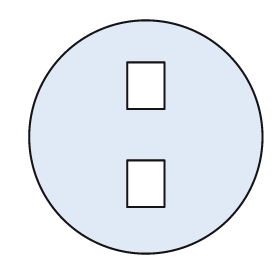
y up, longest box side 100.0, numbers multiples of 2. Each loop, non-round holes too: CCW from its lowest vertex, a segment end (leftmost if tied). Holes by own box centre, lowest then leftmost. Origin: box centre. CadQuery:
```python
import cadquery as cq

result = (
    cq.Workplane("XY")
    .moveTo(0.0, 0.0)
    .circle(50.0)
    .moveTo(-8.0, -30.0)
    .lineTo(8.0, -30.0)
    .lineTo(8.0, -10.0)
    .lineTo(-8.0, -10.0)
    .close()
    .moveTo(-8.0, 12.0)
    .lineTo(8.0, 12.0)
    .lineTo(8.0, 32.0)
    .lineTo(-8.0, 32.0)
    .close()
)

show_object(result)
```